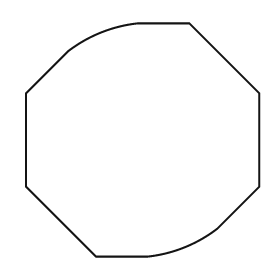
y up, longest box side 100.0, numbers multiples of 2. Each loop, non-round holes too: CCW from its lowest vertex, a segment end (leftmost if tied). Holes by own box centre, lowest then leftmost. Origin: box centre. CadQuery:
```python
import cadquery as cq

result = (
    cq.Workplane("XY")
    .moveTo(-20.0, -50.0)
    .lineTo(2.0, -50.0)
    .threePointArc((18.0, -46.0), (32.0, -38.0))
    .lineTo(50.0, -20.0)
    .lineTo(50.0, 20.0)
    .lineTo(20.0, 50.0)
    .lineTo(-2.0, 50.0)
    .threePointArc((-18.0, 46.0), (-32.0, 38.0))
    .lineTo(-50.0, 20.0)
    .lineTo(-50.0, -20.0)
    .close()
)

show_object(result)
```